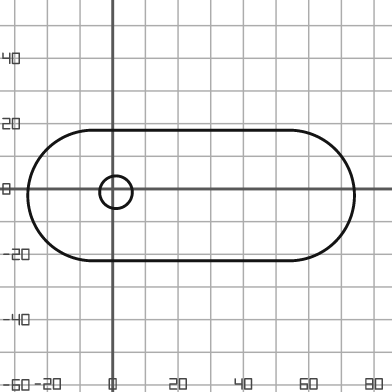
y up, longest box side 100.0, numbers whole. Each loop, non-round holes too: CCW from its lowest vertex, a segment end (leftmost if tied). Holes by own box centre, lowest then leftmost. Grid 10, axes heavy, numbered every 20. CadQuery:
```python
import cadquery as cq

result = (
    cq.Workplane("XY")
    .moveTo(-6.0, -22.0)
    .lineTo(54.0, -22.0)
    .threePointArc((74.0, -2.0), (54.0, 18.0))
    .lineTo(-6.0, 18.0)
    .threePointArc((-26.0, -2.0), (-6.0, -22.0))
    .close()
    .moveTo(1.0, -1.0)
    .circle(5.0)
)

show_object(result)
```